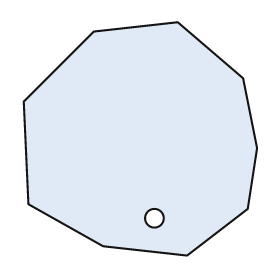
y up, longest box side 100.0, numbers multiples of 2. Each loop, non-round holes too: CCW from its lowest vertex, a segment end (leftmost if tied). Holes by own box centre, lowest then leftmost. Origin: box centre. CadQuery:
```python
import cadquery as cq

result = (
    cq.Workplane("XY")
    .moveTo(20.0, -50.0)
    .lineTo(46.0, -30.0)
    .lineTo(50.0, -4.0)
    .lineTo(44.0, 26.0)
    .lineTo(16.0, 50.0)
    .lineTo(-20.0, 46.0)
    .lineTo(-50.0, 16.0)
    .lineTo(-48.0, -28.0)
    .lineTo(-16.0, -46.0)
    .close()
    .moveTo(6.0, -34.0)
    .circle(4.0)
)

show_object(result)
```